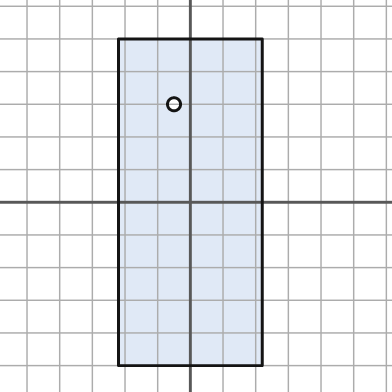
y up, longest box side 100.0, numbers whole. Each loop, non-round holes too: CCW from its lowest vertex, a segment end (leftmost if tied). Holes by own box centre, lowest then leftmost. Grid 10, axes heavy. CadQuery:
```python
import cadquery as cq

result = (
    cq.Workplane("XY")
    .moveTo(-22.0, -50.0)
    .lineTo(22.0, -50.0)
    .lineTo(22.0, 50.0)
    .lineTo(-22.0, 50.0)
    .close()
    .moveTo(-5.0, 30.0)
    .circle(2.0)
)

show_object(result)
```